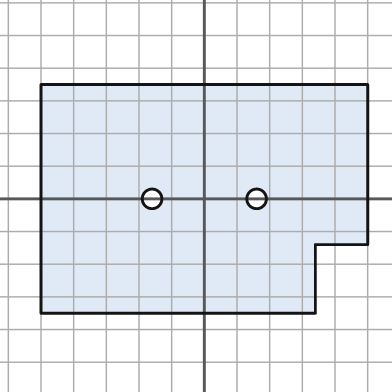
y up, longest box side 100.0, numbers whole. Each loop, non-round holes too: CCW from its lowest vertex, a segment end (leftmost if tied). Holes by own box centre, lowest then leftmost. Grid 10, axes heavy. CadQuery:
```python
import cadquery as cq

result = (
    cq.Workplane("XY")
    .moveTo(-50.0, -35.0)
    .lineTo(34.0, -35.0)
    .lineTo(34.0, -14.0)
    .lineTo(50.0, -14.0)
    .lineTo(50.0, 35.0)
    .lineTo(-50.0, 35.0)
    .close()
    .moveTo(-16.0, 0.0)
    .circle(3.0)
    .moveTo(16.0, 0.0)
    .circle(3.0)
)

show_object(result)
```